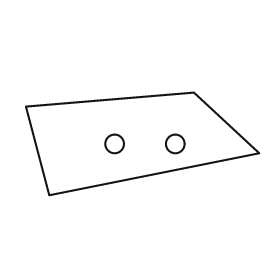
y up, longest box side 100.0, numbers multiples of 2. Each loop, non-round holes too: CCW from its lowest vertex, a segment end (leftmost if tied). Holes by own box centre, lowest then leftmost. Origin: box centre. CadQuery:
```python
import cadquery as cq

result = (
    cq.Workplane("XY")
    .moveTo(-40.0, -22.0)
    .lineTo(50.0, -4.0)
    .lineTo(22.0, 22.0)
    .lineTo(-50.0, 16.0)
    .close()
    .moveTo(-12.0, 0.0)
    .circle(4.0)
    .moveTo(14.0, 0.0)
    .circle(4.0)
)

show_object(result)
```